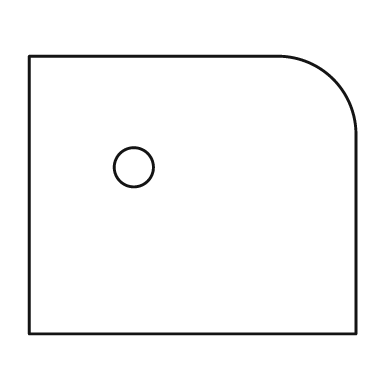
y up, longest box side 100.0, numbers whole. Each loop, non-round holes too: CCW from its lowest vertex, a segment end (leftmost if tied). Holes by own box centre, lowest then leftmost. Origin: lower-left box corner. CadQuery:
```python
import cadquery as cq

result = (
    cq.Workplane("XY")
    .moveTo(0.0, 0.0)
    .lineTo(100.0, 0.0)
    .lineTo(100.0, 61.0)
    .threePointArc((93.0, 78.0), (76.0, 85.0))
    .lineTo(0.0, 85.0)
    .close()
    .moveTo(32.0, 51.0)
    .circle(6.0)
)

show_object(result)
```